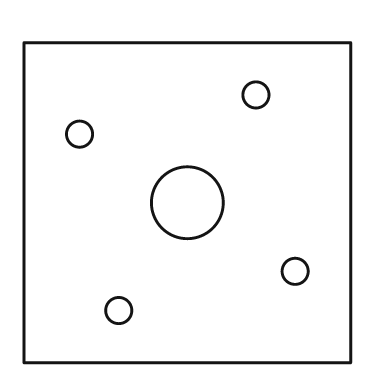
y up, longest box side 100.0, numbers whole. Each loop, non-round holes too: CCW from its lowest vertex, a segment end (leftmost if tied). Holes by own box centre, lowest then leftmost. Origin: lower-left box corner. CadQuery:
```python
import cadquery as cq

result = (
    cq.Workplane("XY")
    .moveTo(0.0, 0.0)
    .lineTo(100.0, 0.0)
    .lineTo(100.0, 98.0)
    .lineTo(0.0, 98.0)
    .close()
    .moveTo(29.0, 16.0)
    .circle(4.0)
    .moveTo(83.0, 28.0)
    .circle(4.0)
    .moveTo(50.0, 49.0)
    .circle(11.0)
    .moveTo(17.0, 70.0)
    .circle(4.0)
    .moveTo(71.0, 82.0)
    .circle(4.0)
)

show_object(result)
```